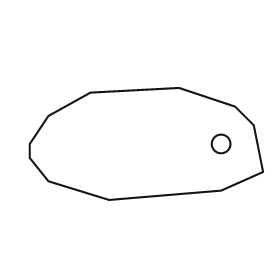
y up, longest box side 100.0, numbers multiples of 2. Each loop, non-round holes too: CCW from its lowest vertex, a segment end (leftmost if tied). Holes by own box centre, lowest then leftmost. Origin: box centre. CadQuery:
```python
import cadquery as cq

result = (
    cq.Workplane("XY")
    .moveTo(-16.0, -24.0)
    .lineTo(32.0, -20.0)
    .lineTo(50.0, -12.0)
    .lineTo(46.0, 8.0)
    .lineTo(38.0, 16.0)
    .lineTo(14.0, 24.0)
    .lineTo(-24.0, 22.0)
    .lineTo(-42.0, 12.0)
    .lineTo(-50.0, 0.0)
    .lineTo(-50.0, -6.0)
    .lineTo(-42.0, -16.0)
    .close()
    .moveTo(32.0, 0.0)
    .circle(4.0)
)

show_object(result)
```